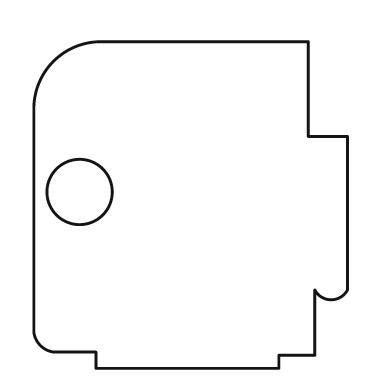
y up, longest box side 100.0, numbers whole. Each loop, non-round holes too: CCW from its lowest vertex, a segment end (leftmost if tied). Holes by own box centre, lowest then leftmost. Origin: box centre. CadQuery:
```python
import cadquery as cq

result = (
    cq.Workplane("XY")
    .moveTo(-29.0, -50.0)
    .lineTo(27.0, -50.0)
    .lineTo(27.0, -46.0)
    .lineTo(38.0, -46.0)
    .lineTo(38.0, -26.0)
    .threePointArc((43.0, -29.0), (48.0, -26.0))
    .lineTo(48.0, 21.0)
    .lineTo(36.0, 21.0)
    .lineTo(36.0, 50.0)
    .lineTo(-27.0, 50.0)
    .threePointArc((-42.0, 44.0), (-48.0, 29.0))
    .lineTo(-48.0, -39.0)
    .threePointArc((-46.0, -43.0), (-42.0, -45.0))
    .lineTo(-29.0, -45.0)
    .close()
    .moveTo(-34.0, 4.0)
    .circle(10.0)
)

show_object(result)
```